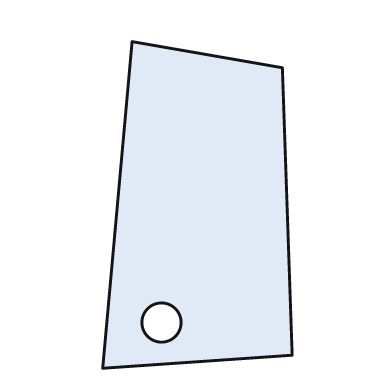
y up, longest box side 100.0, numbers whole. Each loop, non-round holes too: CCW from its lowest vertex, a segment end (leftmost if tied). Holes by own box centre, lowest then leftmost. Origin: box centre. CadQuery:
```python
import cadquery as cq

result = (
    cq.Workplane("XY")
    .moveTo(-29.0, -50.0)
    .lineTo(29.0, -46.0)
    .lineTo(26.0, 42.0)
    .lineTo(-20.0, 50.0)
    .close()
    .moveTo(-11.0, -36.0)
    .circle(6.0)
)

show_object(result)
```